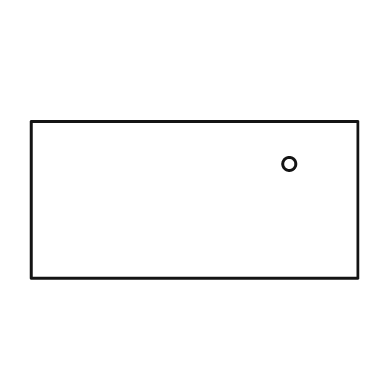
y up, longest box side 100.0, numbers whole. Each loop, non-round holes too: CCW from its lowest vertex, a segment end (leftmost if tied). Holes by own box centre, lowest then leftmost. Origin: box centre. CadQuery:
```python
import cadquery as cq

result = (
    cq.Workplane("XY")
    .moveTo(-50.0, -24.0)
    .lineTo(50.0, -24.0)
    .lineTo(50.0, 24.0)
    .lineTo(-50.0, 24.0)
    .close()
    .moveTo(29.0, 11.0)
    .circle(2.0)
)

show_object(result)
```